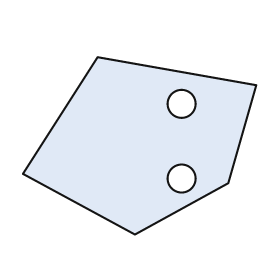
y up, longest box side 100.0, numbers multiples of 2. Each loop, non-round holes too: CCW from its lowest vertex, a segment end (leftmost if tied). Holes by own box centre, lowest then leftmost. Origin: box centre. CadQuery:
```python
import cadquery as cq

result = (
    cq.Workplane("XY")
    .moveTo(-2.0, -38.0)
    .lineTo(38.0, -16.0)
    .lineTo(50.0, 26.0)
    .lineTo(-18.0, 38.0)
    .lineTo(-50.0, -12.0)
    .close()
    .moveTo(18.0, -14.0)
    .circle(6.0)
    .moveTo(18.0, 18.0)
    .circle(6.0)
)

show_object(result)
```